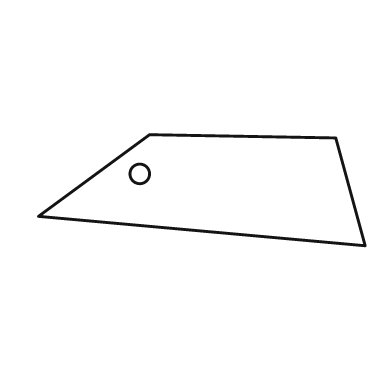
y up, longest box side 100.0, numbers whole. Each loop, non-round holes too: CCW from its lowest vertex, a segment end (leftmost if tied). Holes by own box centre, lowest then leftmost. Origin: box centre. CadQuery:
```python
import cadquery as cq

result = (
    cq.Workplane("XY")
    .moveTo(50.0, -17.0)
    .lineTo(41.0, 16.0)
    .lineTo(-16.0, 17.0)
    .lineTo(-50.0, -8.0)
    .close()
    .moveTo(-19.0, 5.0)
    .circle(3.0)
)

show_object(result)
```